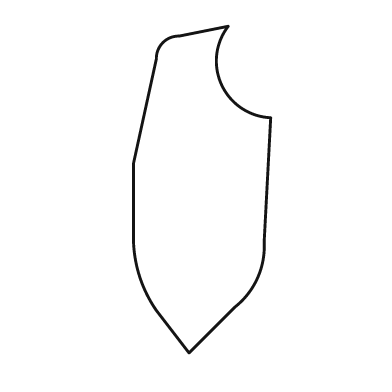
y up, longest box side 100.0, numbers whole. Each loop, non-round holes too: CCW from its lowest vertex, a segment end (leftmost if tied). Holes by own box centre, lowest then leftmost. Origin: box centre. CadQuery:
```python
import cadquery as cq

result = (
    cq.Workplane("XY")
    .moveTo(-4.0, -50.0)
    .lineTo(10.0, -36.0)
    .threePointArc((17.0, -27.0), (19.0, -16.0))
    .lineTo(21.0, 22.0)
    .threePointArc((6.0, 32.0), (8.0, 50.0))
    .lineTo(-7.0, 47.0)
    .threePointArc((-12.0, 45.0), (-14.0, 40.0))
    .lineTo(-21.0, 8.0)
    .lineTo(-21.0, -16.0)
    .threePointArc((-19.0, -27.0), (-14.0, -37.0))
    .close()
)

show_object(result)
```